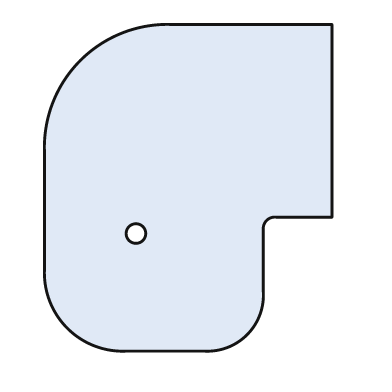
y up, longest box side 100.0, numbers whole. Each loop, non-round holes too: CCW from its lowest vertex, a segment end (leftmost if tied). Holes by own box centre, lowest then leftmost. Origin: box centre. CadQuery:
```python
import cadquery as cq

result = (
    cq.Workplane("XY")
    .moveTo(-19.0, -50.0)
    .lineTo(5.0, -50.0)
    .threePointArc((18.0, -45.0), (23.0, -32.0))
    .lineTo(23.0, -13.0)
    .threePointArc((24.0, -10.0), (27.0, -9.0))
    .lineTo(44.0, -9.0)
    .lineTo(44.0, 50.0)
    .lineTo(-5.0, 50.0)
    .threePointArc((-33.0, 39.0), (-44.0, 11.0))
    .lineTo(-44.0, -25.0)
    .threePointArc((-37.0, -43.0), (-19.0, -50.0))
    .close()
    .moveTo(-16.0, -14.0)
    .circle(3.0)
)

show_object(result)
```